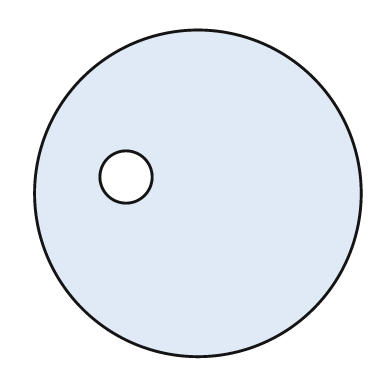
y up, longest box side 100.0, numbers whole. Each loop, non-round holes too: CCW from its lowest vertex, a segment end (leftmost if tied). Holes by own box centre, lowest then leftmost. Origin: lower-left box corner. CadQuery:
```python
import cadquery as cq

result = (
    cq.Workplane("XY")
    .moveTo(50.0, 50.0)
    .circle(50.0)
    .moveTo(28.0, 55.0)
    .circle(8.0)
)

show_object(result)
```